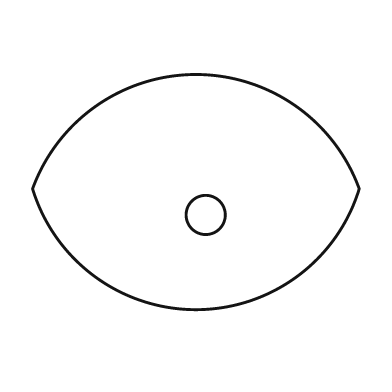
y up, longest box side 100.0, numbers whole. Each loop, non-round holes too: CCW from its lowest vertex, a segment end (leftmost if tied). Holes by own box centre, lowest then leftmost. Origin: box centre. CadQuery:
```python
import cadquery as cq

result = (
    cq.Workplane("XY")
    .moveTo(-50.0, 1.0)
    .threePointArc((0.0, -36.0), (50.0, 1.0))
    .threePointArc((0.0, 36.0), (-50.0, 1.0))
    .close()
    .moveTo(3.0, -7.0)
    .circle(6.0)
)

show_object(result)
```